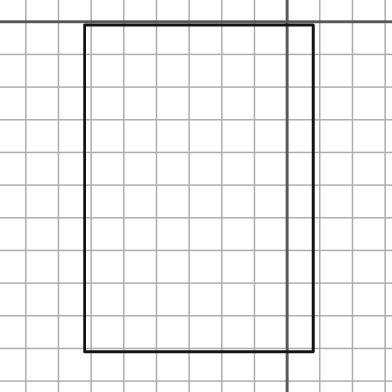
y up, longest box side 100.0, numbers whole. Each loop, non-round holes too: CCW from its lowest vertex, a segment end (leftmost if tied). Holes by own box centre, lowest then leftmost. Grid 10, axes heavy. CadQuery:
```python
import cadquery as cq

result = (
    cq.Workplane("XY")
    .moveTo(-62.0, -101.0)
    .lineTo(8.0, -101.0)
    .lineTo(8.0, -1.0)
    .lineTo(-62.0, -1.0)
    .close()
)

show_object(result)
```